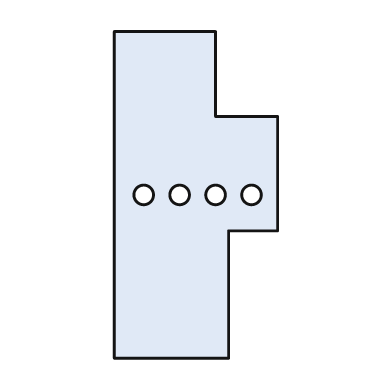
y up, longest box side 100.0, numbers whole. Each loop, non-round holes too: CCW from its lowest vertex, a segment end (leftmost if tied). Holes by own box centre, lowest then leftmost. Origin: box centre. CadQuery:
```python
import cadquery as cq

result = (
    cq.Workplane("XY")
    .moveTo(-25.0, -50.0)
    .lineTo(10.0, -50.0)
    .lineTo(10.0, -11.0)
    .lineTo(25.0, -11.0)
    .lineTo(25.0, 24.0)
    .lineTo(6.0, 24.0)
    .lineTo(6.0, 50.0)
    .lineTo(-25.0, 50.0)
    .close()
    .moveTo(-16.0, 0.0)
    .circle(3.0)
    .moveTo(-5.0, 0.0)
    .circle(3.0)
    .moveTo(6.0, 0.0)
    .circle(3.0)
    .moveTo(17.0, 0.0)
    .circle(3.0)
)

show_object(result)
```